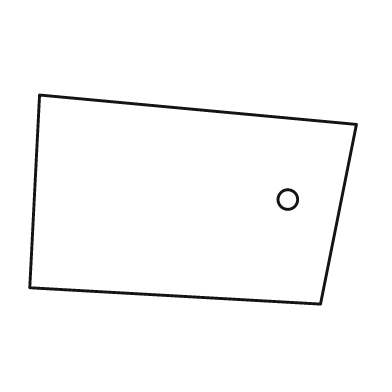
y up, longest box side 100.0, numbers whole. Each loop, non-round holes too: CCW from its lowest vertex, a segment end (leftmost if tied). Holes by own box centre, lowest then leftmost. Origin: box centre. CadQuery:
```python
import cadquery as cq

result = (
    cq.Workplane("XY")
    .moveTo(39.0, -32.0)
    .lineTo(50.0, 23.0)
    .lineTo(-47.0, 32.0)
    .lineTo(-50.0, -27.0)
    .close()
    .moveTo(29.0, 0.0)
    .circle(3.0)
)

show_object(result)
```